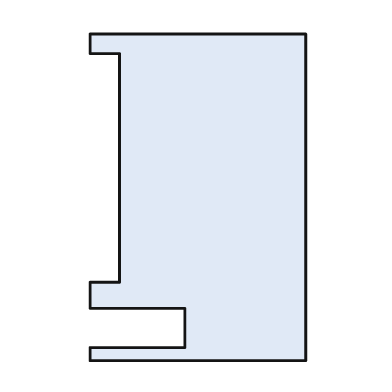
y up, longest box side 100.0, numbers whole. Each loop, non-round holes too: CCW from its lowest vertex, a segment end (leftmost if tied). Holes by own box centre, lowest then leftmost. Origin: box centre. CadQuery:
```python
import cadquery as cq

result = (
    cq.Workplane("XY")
    .moveTo(-33.0, -50.0)
    .lineTo(33.0, -50.0)
    .lineTo(33.0, 50.0)
    .lineTo(-33.0, 50.0)
    .lineTo(-33.0, 44.0)
    .lineTo(-24.0, 44.0)
    .lineTo(-24.0, -26.0)
    .lineTo(-33.0, -26.0)
    .lineTo(-33.0, -34.0)
    .lineTo(-4.0, -34.0)
    .lineTo(-4.0, -46.0)
    .lineTo(-33.0, -46.0)
    .close()
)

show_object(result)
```